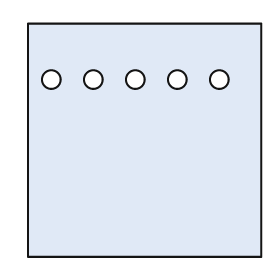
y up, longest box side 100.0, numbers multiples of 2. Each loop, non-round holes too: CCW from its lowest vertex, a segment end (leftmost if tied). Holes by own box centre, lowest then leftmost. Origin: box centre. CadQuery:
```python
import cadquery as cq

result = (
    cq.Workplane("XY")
    .moveTo(-50.0, -50.0)
    .lineTo(50.0, -50.0)
    .lineTo(50.0, 50.0)
    .lineTo(-50.0, 50.0)
    .close()
    .moveTo(-40.0, 26.0)
    .circle(4.0)
    .moveTo(-22.0, 26.0)
    .circle(4.0)
    .moveTo(-4.0, 26.0)
    .circle(4.0)
    .moveTo(14.0, 26.0)
    .circle(4.0)
    .moveTo(32.0, 26.0)
    .circle(4.0)
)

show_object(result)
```